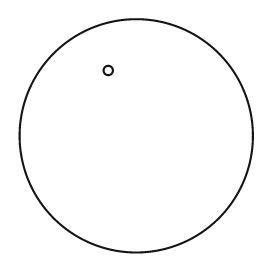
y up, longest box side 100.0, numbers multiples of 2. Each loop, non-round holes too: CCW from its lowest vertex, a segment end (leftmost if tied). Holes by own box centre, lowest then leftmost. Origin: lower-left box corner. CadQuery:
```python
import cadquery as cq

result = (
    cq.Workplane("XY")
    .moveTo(50.0, 50.0)
    .circle(50.0)
    .moveTo(38.0, 78.0)
    .circle(2.0)
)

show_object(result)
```